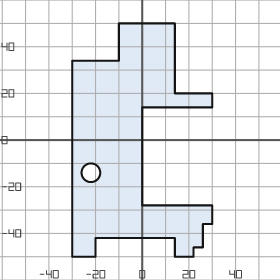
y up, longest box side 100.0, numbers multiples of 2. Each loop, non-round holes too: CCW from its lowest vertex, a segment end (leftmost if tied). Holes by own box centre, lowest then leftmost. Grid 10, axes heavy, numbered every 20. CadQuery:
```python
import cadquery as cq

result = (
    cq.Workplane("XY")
    .moveTo(-30.0, -50.0)
    .lineTo(-20.0, -50.0)
    .lineTo(-20.0, -42.0)
    .lineTo(14.0, -42.0)
    .lineTo(14.0, -50.0)
    .lineTo(22.0, -50.0)
    .lineTo(22.0, -46.0)
    .lineTo(26.0, -46.0)
    .lineTo(26.0, -36.0)
    .lineTo(30.0, -36.0)
    .lineTo(30.0, -28.0)
    .lineTo(0.0, -28.0)
    .lineTo(0.0, 14.0)
    .lineTo(30.0, 14.0)
    .lineTo(30.0, 20.0)
    .lineTo(14.0, 20.0)
    .lineTo(14.0, 50.0)
    .lineTo(-10.0, 50.0)
    .lineTo(-10.0, 34.0)
    .lineTo(-30.0, 34.0)
    .close()
    .moveTo(-22.0, -14.0)
    .circle(4.0)
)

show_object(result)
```